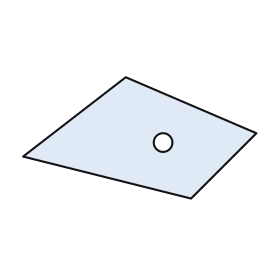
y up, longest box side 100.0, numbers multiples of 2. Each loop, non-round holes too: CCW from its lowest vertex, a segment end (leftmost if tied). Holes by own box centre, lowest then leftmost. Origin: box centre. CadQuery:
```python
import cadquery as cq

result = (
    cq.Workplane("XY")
    .moveTo(22.0, -26.0)
    .lineTo(50.0, 2.0)
    .lineTo(-6.0, 26.0)
    .lineTo(-50.0, -8.0)
    .close()
    .moveTo(10.0, -2.0)
    .circle(4.0)
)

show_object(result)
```